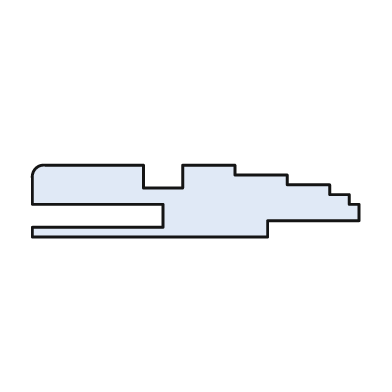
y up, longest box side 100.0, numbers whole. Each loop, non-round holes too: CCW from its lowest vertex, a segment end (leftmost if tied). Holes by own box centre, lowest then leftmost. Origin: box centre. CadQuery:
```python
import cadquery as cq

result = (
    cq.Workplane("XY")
    .moveTo(-50.0, -11.0)
    .lineTo(22.0, -11.0)
    .lineTo(22.0, -6.0)
    .lineTo(50.0, -6.0)
    .lineTo(50.0, -1.0)
    .lineTo(47.0, -1.0)
    .lineTo(47.0, 2.0)
    .lineTo(41.0, 2.0)
    .lineTo(41.0, 5.0)
    .lineTo(28.0, 5.0)
    .lineTo(28.0, 8.0)
    .lineTo(12.0, 8.0)
    .lineTo(12.0, 11.0)
    .lineTo(-4.0, 11.0)
    .lineTo(-4.0, 4.0)
    .lineTo(-16.0, 4.0)
    .lineTo(-16.0, 11.0)
    .lineTo(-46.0, 11.0)
    .threePointArc((-49.0, 10.0), (-50.0, 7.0))
    .lineTo(-50.0, -1.0)
    .lineTo(-10.0, -1.0)
    .lineTo(-10.0, -8.0)
    .lineTo(-50.0, -8.0)
    .close()
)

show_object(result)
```